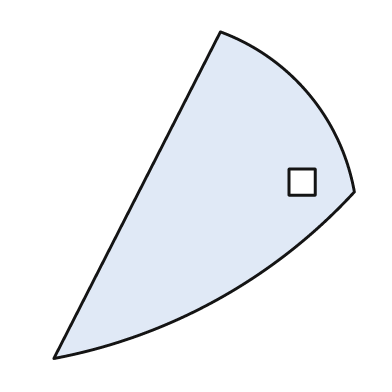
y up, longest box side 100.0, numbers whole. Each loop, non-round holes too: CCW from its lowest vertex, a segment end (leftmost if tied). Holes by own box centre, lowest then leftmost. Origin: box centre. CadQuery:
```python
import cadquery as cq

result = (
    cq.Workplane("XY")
    .moveTo(-46.0, -50.0)
    .threePointArc((4.0, -32.0), (46.0, 1.0))
    .threePointArc((32.0, 31.0), (5.0, 50.0))
    .close()
    .moveTo(26.0, 0.0)
    .lineTo(34.0, 0.0)
    .lineTo(34.0, 8.0)
    .lineTo(26.0, 8.0)
    .close()
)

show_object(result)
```